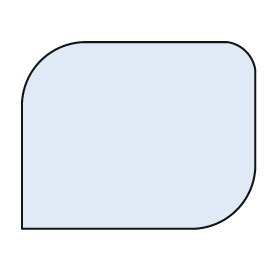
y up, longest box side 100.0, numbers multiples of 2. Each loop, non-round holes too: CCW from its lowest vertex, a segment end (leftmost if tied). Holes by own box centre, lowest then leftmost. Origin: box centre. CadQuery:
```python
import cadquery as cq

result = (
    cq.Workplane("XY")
    .moveTo(-50.0, -40.0)
    .lineTo(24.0, -40.0)
    .threePointArc((42.0, -32.0), (50.0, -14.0))
    .lineTo(50.0, 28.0)
    .threePointArc((46.0, 36.0), (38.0, 40.0))
    .lineTo(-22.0, 40.0)
    .threePointArc((-42.0, 32.0), (-50.0, 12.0))
    .close()
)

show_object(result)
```